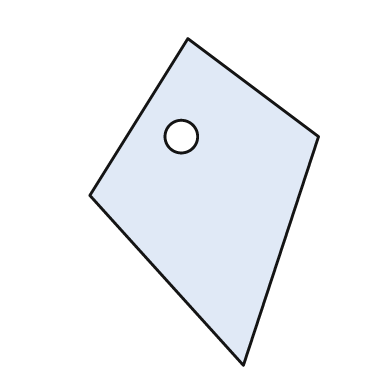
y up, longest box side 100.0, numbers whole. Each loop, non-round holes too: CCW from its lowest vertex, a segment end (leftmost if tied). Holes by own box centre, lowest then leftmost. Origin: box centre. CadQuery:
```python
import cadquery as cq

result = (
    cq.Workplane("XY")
    .moveTo(12.0, -50.0)
    .lineTo(35.0, 20.0)
    .lineTo(-5.0, 50.0)
    .lineTo(-35.0, 2.0)
    .close()
    .moveTo(-7.0, 20.0)
    .circle(5.0)
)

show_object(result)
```